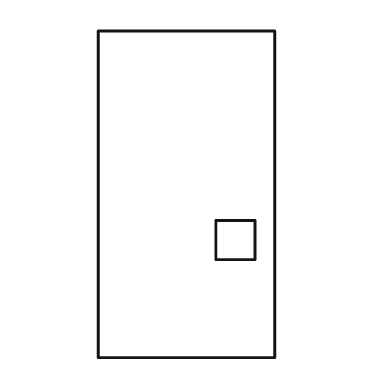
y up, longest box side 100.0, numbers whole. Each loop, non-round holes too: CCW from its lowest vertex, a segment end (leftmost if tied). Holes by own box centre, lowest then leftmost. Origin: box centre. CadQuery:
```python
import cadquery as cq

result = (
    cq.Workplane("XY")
    .moveTo(-27.0, -50.0)
    .lineTo(27.0, -50.0)
    .lineTo(27.0, 50.0)
    .lineTo(-27.0, 50.0)
    .close()
    .moveTo(9.0, -20.0)
    .lineTo(21.0, -20.0)
    .lineTo(21.0, -8.0)
    .lineTo(9.0, -8.0)
    .close()
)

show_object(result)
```